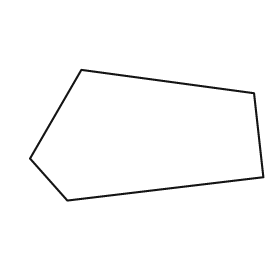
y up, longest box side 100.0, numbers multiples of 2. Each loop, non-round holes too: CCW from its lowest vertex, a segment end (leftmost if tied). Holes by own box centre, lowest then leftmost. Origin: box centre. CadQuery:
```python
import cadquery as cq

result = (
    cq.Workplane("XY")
    .moveTo(-34.0, -28.0)
    .lineTo(50.0, -18.0)
    .lineTo(46.0, 18.0)
    .lineTo(-28.0, 28.0)
    .lineTo(-50.0, -10.0)
    .close()
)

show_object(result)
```